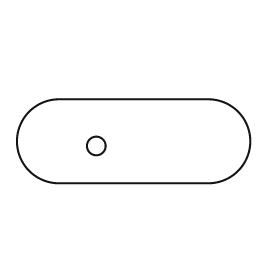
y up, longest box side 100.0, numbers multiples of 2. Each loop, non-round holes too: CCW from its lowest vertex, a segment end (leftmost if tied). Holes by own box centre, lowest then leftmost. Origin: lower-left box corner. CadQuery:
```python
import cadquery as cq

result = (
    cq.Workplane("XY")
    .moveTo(18.0, 0.0)
    .lineTo(82.0, 0.0)
    .threePointArc((100.0, 18.0), (82.0, 36.0))
    .lineTo(18.0, 36.0)
    .threePointArc((0.0, 18.0), (18.0, 0.0))
    .close()
    .moveTo(34.0, 16.0)
    .circle(4.0)
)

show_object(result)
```